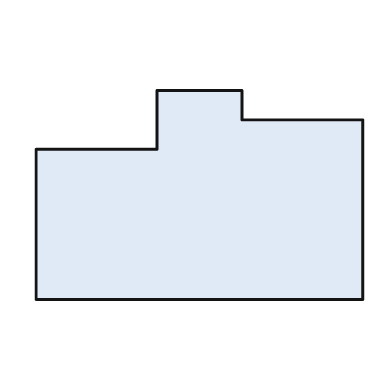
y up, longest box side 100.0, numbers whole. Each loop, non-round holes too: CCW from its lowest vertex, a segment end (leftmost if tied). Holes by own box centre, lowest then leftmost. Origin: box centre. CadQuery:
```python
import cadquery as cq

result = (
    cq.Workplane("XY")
    .moveTo(-50.0, -32.0)
    .lineTo(50.0, -32.0)
    .lineTo(50.0, 23.0)
    .lineTo(13.0, 23.0)
    .lineTo(13.0, 32.0)
    .lineTo(-13.0, 32.0)
    .lineTo(-13.0, 14.0)
    .lineTo(-50.0, 14.0)
    .close()
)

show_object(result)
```